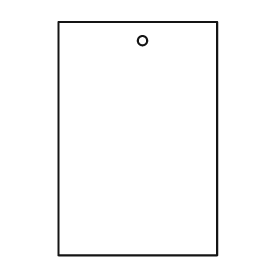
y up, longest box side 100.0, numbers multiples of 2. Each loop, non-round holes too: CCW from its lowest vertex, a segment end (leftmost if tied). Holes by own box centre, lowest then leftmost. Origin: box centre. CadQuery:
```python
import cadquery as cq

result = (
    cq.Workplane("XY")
    .moveTo(-34.0, -50.0)
    .lineTo(34.0, -50.0)
    .lineTo(34.0, 50.0)
    .lineTo(-34.0, 50.0)
    .close()
    .moveTo(2.0, 42.0)
    .circle(2.0)
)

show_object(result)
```